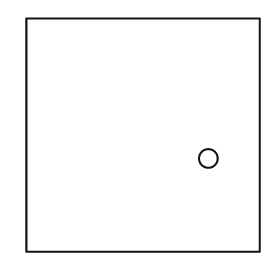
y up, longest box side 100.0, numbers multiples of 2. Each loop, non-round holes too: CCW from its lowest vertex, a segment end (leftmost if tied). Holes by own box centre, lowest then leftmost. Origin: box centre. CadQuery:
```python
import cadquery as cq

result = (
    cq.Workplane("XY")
    .moveTo(-50.0, -50.0)
    .lineTo(50.0, -50.0)
    .lineTo(50.0, 50.0)
    .lineTo(-50.0, 50.0)
    .close()
    .moveTo(28.0, -10.0)
    .circle(4.0)
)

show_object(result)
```